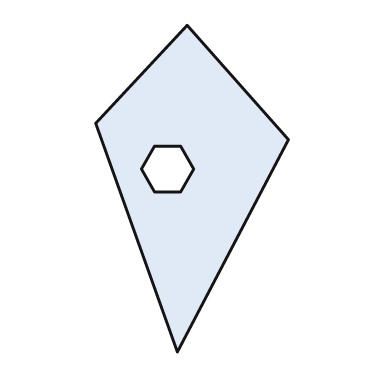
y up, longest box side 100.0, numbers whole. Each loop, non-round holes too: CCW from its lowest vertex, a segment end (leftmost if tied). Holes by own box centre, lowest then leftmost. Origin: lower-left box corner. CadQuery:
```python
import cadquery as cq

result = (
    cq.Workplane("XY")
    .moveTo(25.0, 0.0)
    .lineTo(59.0, 65.0)
    .lineTo(28.0, 100.0)
    .lineTo(0.0, 70.0)
    .close()
    .moveTo(18.0, 49.0)
    .lineTo(26.0, 49.0)
    .lineTo(30.0, 56.0)
    .lineTo(26.0, 63.0)
    .lineTo(18.0, 63.0)
    .lineTo(14.0, 56.0)
    .close()
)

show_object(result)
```